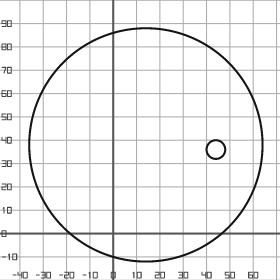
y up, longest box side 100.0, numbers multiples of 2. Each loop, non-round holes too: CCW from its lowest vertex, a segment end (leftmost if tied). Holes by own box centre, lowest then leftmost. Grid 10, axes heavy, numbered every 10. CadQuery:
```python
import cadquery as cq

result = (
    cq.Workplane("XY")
    .moveTo(14.0, 38.0)
    .circle(50.0)
    .moveTo(44.0, 36.0)
    .circle(4.0)
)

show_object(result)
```